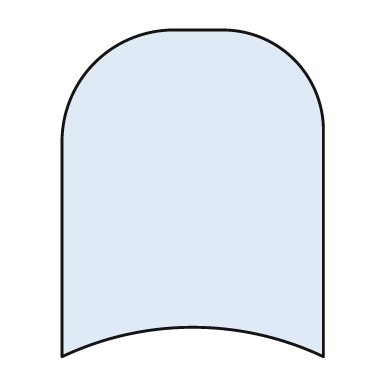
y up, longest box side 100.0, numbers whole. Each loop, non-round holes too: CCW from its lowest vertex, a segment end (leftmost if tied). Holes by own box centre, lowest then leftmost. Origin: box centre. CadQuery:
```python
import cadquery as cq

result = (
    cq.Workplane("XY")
    .moveTo(-40.0, -50.0)
    .threePointArc((0.0, -41.0), (40.0, -50.0))
    .lineTo(40.0, 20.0)
    .threePointArc((31.0, 41.0), (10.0, 50.0))
    .lineTo(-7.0, 50.0)
    .threePointArc((-30.0, 40.0), (-40.0, 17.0))
    .close()
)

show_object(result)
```